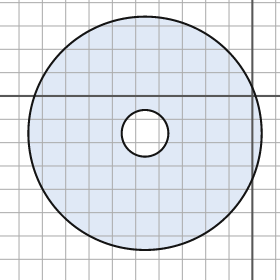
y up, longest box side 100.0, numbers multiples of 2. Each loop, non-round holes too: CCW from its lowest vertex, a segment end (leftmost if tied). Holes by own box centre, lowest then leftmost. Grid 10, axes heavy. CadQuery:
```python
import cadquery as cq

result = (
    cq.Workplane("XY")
    .moveTo(-46.0, -16.0)
    .circle(50.0)
    .moveTo(-46.0, -16.0)
    .circle(10.0)
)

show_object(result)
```